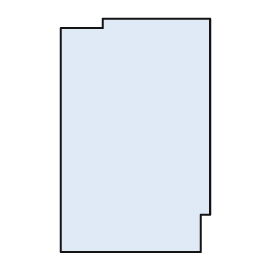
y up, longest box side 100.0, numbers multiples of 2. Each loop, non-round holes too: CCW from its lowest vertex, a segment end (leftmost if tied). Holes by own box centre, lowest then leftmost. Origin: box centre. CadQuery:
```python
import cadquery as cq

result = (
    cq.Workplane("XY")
    .moveTo(-32.0, -50.0)
    .lineTo(28.0, -50.0)
    .lineTo(28.0, -34.0)
    .lineTo(32.0, -34.0)
    .lineTo(32.0, 50.0)
    .lineTo(-14.0, 50.0)
    .lineTo(-14.0, 46.0)
    .lineTo(-32.0, 46.0)
    .close()
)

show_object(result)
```